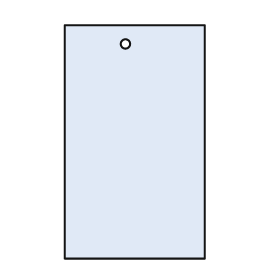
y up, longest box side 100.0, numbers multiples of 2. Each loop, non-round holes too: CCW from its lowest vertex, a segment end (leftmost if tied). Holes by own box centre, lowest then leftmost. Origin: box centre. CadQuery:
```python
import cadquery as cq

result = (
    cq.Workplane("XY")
    .moveTo(-30.0, -50.0)
    .lineTo(30.0, -50.0)
    .lineTo(30.0, 50.0)
    .lineTo(-30.0, 50.0)
    .close()
    .moveTo(-4.0, 42.0)
    .circle(2.0)
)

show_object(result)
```